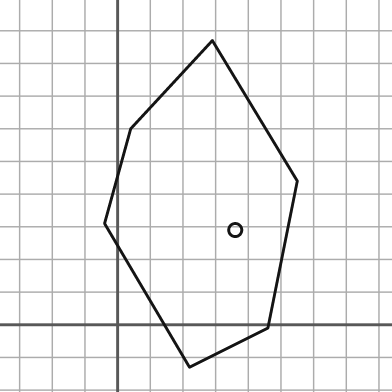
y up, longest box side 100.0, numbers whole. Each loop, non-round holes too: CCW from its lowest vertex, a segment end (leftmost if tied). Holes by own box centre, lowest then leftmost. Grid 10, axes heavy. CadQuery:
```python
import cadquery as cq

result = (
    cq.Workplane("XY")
    .moveTo(22.0, -13.0)
    .lineTo(46.0, -1.0)
    .lineTo(55.0, 44.0)
    .lineTo(29.0, 87.0)
    .lineTo(4.0, 60.0)
    .lineTo(-4.0, 31.0)
    .close()
    .moveTo(36.0, 29.0)
    .circle(2.0)
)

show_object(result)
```